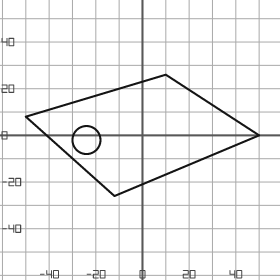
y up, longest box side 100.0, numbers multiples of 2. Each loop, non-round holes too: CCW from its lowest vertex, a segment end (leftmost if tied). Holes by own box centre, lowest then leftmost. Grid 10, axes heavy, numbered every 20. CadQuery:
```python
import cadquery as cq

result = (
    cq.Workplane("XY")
    .moveTo(-12.0, -26.0)
    .lineTo(50.0, 0.0)
    .lineTo(10.0, 26.0)
    .lineTo(-50.0, 8.0)
    .close()
    .moveTo(-24.0, -2.0)
    .circle(6.0)
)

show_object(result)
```